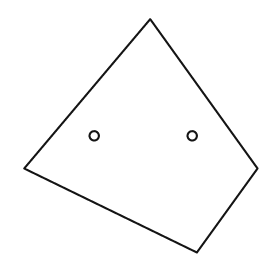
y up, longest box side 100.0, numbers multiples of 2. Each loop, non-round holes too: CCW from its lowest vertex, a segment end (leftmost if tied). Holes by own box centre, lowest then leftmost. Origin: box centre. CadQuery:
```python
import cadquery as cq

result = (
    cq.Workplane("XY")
    .moveTo(24.0, -50.0)
    .lineTo(50.0, -14.0)
    .lineTo(4.0, 50.0)
    .lineTo(-50.0, -14.0)
    .close()
    .moveTo(-20.0, 0.0)
    .circle(2.0)
    .moveTo(22.0, 0.0)
    .circle(2.0)
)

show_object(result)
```